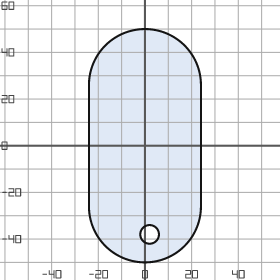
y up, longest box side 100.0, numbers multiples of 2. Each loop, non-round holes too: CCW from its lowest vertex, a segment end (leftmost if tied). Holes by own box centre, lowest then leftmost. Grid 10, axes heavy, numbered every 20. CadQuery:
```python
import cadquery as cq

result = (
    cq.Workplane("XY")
    .moveTo(-24.0, -26.0)
    .threePointArc((0.0, -50.0), (24.0, -26.0))
    .lineTo(24.0, 26.0)
    .threePointArc((0.0, 50.0), (-24.0, 26.0))
    .close()
    .moveTo(2.0, -38.0)
    .circle(4.0)
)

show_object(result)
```